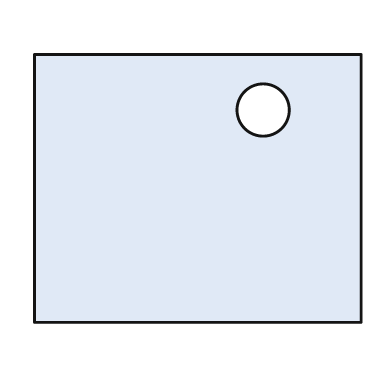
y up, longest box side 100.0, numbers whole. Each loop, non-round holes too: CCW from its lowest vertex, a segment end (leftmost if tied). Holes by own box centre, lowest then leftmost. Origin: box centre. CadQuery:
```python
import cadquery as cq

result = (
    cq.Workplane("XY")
    .moveTo(-50.0, -41.0)
    .lineTo(50.0, -41.0)
    .lineTo(50.0, 41.0)
    .lineTo(-50.0, 41.0)
    .close()
    .moveTo(20.0, 24.0)
    .circle(8.0)
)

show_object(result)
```